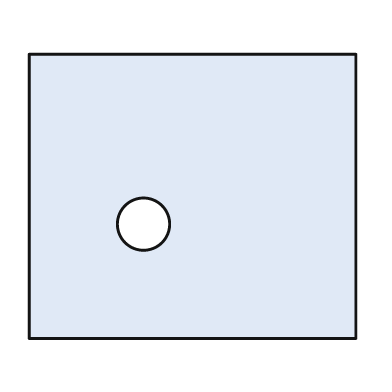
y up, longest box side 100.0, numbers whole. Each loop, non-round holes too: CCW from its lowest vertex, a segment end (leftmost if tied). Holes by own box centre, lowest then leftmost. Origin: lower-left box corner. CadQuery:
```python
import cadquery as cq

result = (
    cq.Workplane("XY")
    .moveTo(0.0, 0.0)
    .lineTo(100.0, 0.0)
    .lineTo(100.0, 87.0)
    .lineTo(0.0, 87.0)
    .close()
    .moveTo(35.0, 35.0)
    .circle(8.0)
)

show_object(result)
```